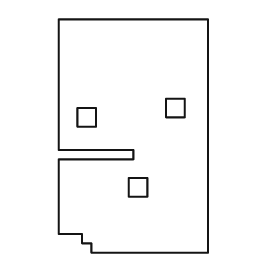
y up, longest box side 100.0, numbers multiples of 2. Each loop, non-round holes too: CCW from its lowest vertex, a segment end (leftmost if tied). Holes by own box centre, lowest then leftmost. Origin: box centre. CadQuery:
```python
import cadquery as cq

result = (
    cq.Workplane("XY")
    .moveTo(-18.0, -50.0)
    .lineTo(32.0, -50.0)
    .lineTo(32.0, 50.0)
    .lineTo(-32.0, 50.0)
    .lineTo(-32.0, -6.0)
    .lineTo(0.0, -6.0)
    .lineTo(0.0, -10.0)
    .lineTo(-32.0, -10.0)
    .lineTo(-32.0, -42.0)
    .lineTo(-22.0, -42.0)
    .lineTo(-22.0, -46.0)
    .lineTo(-18.0, -46.0)
    .close()
    .moveTo(-2.0, -26.0)
    .lineTo(6.0, -26.0)
    .lineTo(6.0, -18.0)
    .lineTo(-2.0, -18.0)
    .close()
    .moveTo(-24.0, 4.0)
    .lineTo(-16.0, 4.0)
    .lineTo(-16.0, 12.0)
    .lineTo(-24.0, 12.0)
    .close()
    .moveTo(14.0, 8.0)
    .lineTo(22.0, 8.0)
    .lineTo(22.0, 16.0)
    .lineTo(14.0, 16.0)
    .close()
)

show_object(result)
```